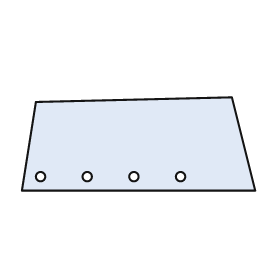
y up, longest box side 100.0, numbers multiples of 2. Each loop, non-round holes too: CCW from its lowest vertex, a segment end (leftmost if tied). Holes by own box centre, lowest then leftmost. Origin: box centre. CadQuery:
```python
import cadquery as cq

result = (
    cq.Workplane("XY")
    .moveTo(-50.0, -20.0)
    .lineTo(50.0, -20.0)
    .lineTo(40.0, 20.0)
    .lineTo(-44.0, 18.0)
    .close()
    .moveTo(-42.0, -14.0)
    .circle(2.0)
    .moveTo(-22.0, -14.0)
    .circle(2.0)
    .moveTo(-2.0, -14.0)
    .circle(2.0)
    .moveTo(18.0, -14.0)
    .circle(2.0)
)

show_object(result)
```